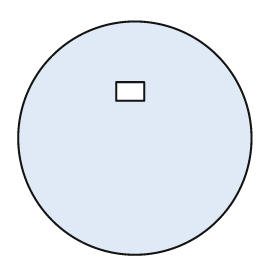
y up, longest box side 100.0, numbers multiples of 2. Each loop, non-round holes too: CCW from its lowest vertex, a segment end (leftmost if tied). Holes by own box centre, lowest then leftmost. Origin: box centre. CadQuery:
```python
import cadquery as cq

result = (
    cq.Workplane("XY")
    .moveTo(0.0, 0.0)
    .circle(50.0)
    .moveTo(-8.0, 16.0)
    .lineTo(4.0, 16.0)
    .lineTo(4.0, 24.0)
    .lineTo(-8.0, 24.0)
    .close()
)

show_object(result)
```